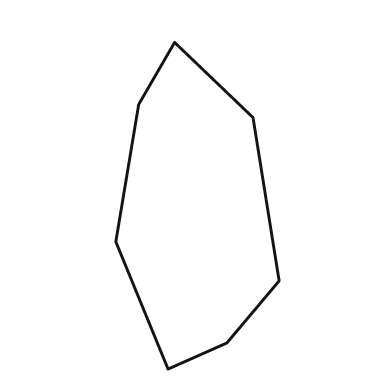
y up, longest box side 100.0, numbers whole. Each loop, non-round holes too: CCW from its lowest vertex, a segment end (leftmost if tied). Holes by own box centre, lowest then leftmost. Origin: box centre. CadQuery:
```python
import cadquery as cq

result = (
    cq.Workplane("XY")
    .moveTo(-9.0, -50.0)
    .lineTo(9.0, -42.0)
    .lineTo(25.0, -23.0)
    .lineTo(17.0, 27.0)
    .lineTo(-7.0, 50.0)
    .lineTo(-18.0, 31.0)
    .lineTo(-25.0, -11.0)
    .close()
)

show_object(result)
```